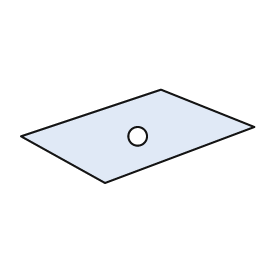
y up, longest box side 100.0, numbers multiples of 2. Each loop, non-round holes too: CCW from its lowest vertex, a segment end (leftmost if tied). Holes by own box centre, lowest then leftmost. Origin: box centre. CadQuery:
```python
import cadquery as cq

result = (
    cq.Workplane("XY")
    .moveTo(-14.0, -20.0)
    .lineTo(50.0, 4.0)
    .lineTo(10.0, 20.0)
    .lineTo(-50.0, 0.0)
    .close()
    .moveTo(0.0, 0.0)
    .circle(4.0)
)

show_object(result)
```